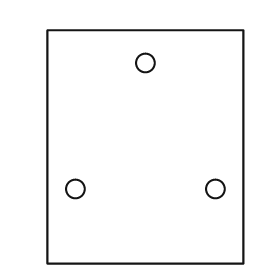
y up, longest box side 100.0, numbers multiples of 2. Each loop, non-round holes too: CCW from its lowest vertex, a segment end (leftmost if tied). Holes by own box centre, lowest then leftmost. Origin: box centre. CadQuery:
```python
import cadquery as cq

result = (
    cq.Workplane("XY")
    .moveTo(-42.0, -50.0)
    .lineTo(42.0, -50.0)
    .lineTo(42.0, 50.0)
    .lineTo(-42.0, 50.0)
    .close()
    .moveTo(-30.0, -18.0)
    .circle(4.0)
    .moveTo(30.0, -18.0)
    .circle(4.0)
    .moveTo(0.0, 36.0)
    .circle(4.0)
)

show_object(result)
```